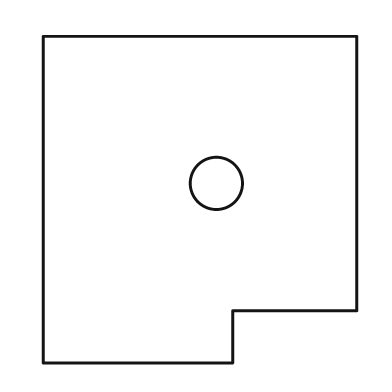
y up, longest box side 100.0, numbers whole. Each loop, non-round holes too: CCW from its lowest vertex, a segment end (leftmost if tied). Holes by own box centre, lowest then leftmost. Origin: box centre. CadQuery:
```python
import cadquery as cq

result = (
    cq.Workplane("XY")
    .moveTo(-48.0, -50.0)
    .lineTo(10.0, -50.0)
    .lineTo(10.0, -34.0)
    .lineTo(48.0, -34.0)
    .lineTo(48.0, 50.0)
    .lineTo(-48.0, 50.0)
    .close()
    .moveTo(5.0, 5.0)
    .circle(8.0)
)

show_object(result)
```